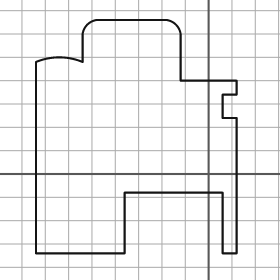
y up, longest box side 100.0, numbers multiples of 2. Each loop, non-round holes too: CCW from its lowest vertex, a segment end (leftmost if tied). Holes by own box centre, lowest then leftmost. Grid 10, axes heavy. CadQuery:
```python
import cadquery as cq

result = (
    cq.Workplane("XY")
    .moveTo(-74.0, -34.0)
    .lineTo(-36.0, -34.0)
    .lineTo(-36.0, -8.0)
    .lineTo(6.0, -8.0)
    .lineTo(6.0, -34.0)
    .lineTo(12.0, -34.0)
    .lineTo(12.0, 24.0)
    .lineTo(6.0, 24.0)
    .lineTo(6.0, 34.0)
    .lineTo(12.0, 34.0)
    .lineTo(12.0, 40.0)
    .lineTo(-12.0, 40.0)
    .lineTo(-12.0, 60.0)
    .threePointArc((-14.0, 64.0), (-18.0, 66.0))
    .lineTo(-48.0, 66.0)
    .threePointArc((-52.0, 64.0), (-54.0, 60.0))
    .lineTo(-54.0, 48.0)
    .threePointArc((-64.0, 50.0), (-74.0, 48.0))
    .close()
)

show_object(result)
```